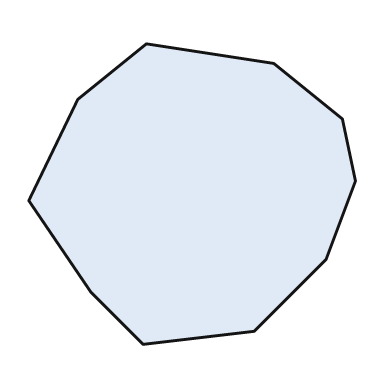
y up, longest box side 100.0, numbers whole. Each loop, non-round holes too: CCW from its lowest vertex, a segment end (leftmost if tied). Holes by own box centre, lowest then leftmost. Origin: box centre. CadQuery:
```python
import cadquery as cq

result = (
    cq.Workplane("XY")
    .moveTo(-15.0, -46.0)
    .lineTo(19.0, -42.0)
    .lineTo(41.0, -20.0)
    .lineTo(50.0, 4.0)
    .lineTo(46.0, 23.0)
    .lineTo(25.0, 40.0)
    .lineTo(-14.0, 46.0)
    .lineTo(-35.0, 29.0)
    .lineTo(-50.0, -2.0)
    .lineTo(-31.0, -30.0)
    .close()
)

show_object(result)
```